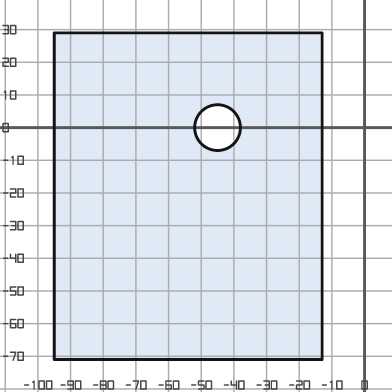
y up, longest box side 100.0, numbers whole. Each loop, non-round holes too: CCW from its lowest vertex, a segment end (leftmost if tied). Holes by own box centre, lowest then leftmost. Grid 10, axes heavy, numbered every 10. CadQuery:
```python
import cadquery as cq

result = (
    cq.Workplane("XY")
    .moveTo(-95.0, -71.0)
    .lineTo(-13.0, -71.0)
    .lineTo(-13.0, 29.0)
    .lineTo(-95.0, 29.0)
    .close()
    .moveTo(-45.0, 0.0)
    .circle(7.0)
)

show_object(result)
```